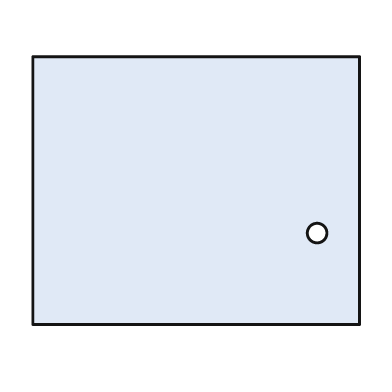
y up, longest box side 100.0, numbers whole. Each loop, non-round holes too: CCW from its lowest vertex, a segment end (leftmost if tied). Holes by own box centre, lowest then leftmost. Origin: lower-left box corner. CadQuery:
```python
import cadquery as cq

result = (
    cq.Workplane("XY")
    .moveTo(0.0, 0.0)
    .lineTo(100.0, 0.0)
    .lineTo(100.0, 82.0)
    .lineTo(0.0, 82.0)
    .close()
    .moveTo(87.0, 28.0)
    .circle(3.0)
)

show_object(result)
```